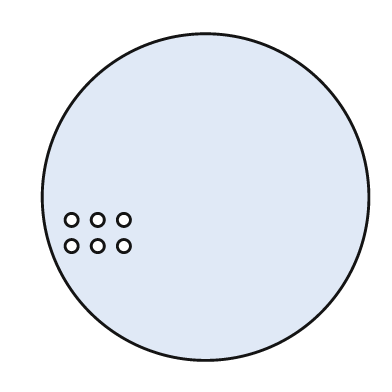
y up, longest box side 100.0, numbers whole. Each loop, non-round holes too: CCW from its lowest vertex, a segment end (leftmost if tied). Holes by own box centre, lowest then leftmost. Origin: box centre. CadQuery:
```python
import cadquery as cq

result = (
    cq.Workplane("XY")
    .moveTo(0.0, 0.0)
    .circle(50.0)
    .moveTo(-41.0, -15.0)
    .circle(2.0)
    .moveTo(-33.0, -15.0)
    .circle(2.0)
    .moveTo(-25.0, -15.0)
    .circle(2.0)
    .moveTo(-41.0, -7.0)
    .circle(2.0)
    .moveTo(-33.0, -7.0)
    .circle(2.0)
    .moveTo(-25.0, -7.0)
    .circle(2.0)
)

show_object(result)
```